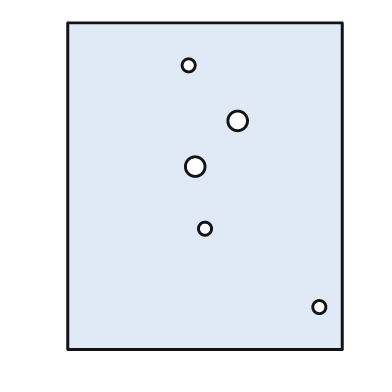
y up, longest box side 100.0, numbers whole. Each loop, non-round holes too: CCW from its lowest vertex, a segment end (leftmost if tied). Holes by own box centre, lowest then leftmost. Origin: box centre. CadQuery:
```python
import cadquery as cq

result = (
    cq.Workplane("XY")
    .moveTo(-42.0, -50.0)
    .lineTo(42.0, -50.0)
    .lineTo(42.0, 50.0)
    .lineTo(-42.0, 50.0)
    .close()
    .moveTo(35.0, -37.0)
    .circle(2.0)
    .moveTo(0.0, -13.0)
    .circle(2.0)
    .moveTo(-3.0, 6.0)
    .circle(3.0)
    .moveTo(10.0, 20.0)
    .circle(3.0)
    .moveTo(-5.0, 37.0)
    .circle(2.0)
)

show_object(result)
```